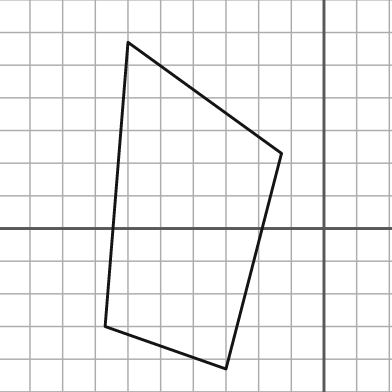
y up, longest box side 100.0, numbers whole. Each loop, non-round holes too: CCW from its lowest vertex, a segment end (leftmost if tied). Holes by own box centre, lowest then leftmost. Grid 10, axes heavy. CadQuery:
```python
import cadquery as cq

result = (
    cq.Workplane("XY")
    .moveTo(-30.0, -43.0)
    .lineTo(-13.0, 23.0)
    .lineTo(-60.0, 57.0)
    .lineTo(-67.0, -30.0)
    .close()
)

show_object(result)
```